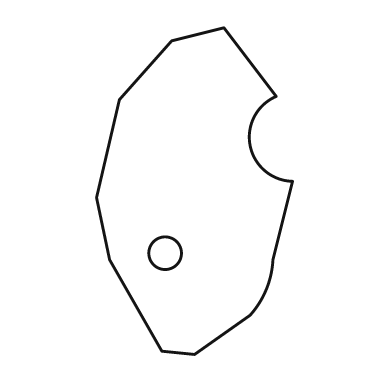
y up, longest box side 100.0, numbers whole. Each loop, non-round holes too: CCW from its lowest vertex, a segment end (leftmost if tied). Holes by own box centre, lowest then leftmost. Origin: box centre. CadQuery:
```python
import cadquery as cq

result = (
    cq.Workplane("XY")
    .moveTo(0.0, -50.0)
    .lineTo(17.0, -38.0)
    .threePointArc((22.0, -30.0), (24.0, -21.0))
    .lineTo(30.0, 3.0)
    .threePointArc((17.0, 14.0), (25.0, 29.0))
    .lineTo(9.0, 50.0)
    .lineTo(-7.0, 46.0)
    .lineTo(-23.0, 28.0)
    .lineTo(-30.0, -2.0)
    .lineTo(-26.0, -21.0)
    .lineTo(-10.0, -49.0)
    .close()
    .moveTo(-9.0, -19.0)
    .circle(5.0)
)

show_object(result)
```